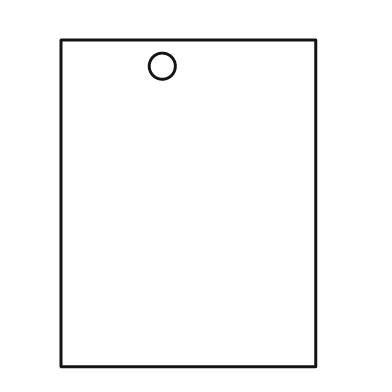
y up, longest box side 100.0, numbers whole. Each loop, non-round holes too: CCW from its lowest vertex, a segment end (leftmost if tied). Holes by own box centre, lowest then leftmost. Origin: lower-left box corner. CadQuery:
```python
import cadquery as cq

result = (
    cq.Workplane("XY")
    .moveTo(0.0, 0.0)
    .lineTo(78.0, 0.0)
    .lineTo(78.0, 100.0)
    .lineTo(0.0, 100.0)
    .close()
    .moveTo(31.0, 92.0)
    .circle(4.0)
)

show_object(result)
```